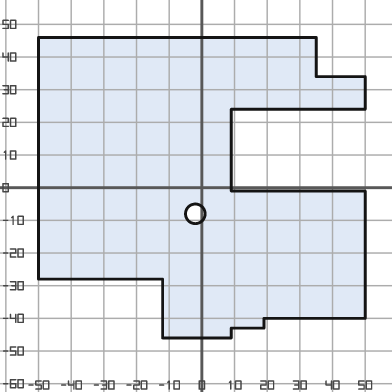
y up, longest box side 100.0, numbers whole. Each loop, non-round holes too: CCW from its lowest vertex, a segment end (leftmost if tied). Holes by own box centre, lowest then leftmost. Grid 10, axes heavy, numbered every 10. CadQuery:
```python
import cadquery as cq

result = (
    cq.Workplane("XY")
    .moveTo(-12.0, -46.0)
    .lineTo(9.0, -46.0)
    .lineTo(9.0, -43.0)
    .lineTo(19.0, -43.0)
    .lineTo(19.0, -40.0)
    .lineTo(50.0, -40.0)
    .lineTo(50.0, -1.0)
    .lineTo(9.0, -1.0)
    .lineTo(9.0, 24.0)
    .lineTo(50.0, 24.0)
    .lineTo(50.0, 34.0)
    .lineTo(35.0, 34.0)
    .lineTo(35.0, 46.0)
    .lineTo(-50.0, 46.0)
    .lineTo(-50.0, -28.0)
    .lineTo(-12.0, -28.0)
    .close()
    .moveTo(-2.0, -8.0)
    .circle(3.0)
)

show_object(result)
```